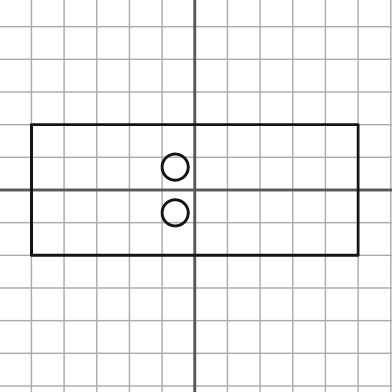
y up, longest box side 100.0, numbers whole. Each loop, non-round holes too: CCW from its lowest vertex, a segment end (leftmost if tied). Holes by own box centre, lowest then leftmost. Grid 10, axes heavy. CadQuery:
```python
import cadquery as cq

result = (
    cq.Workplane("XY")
    .moveTo(-50.0, -20.0)
    .lineTo(50.0, -20.0)
    .lineTo(50.0, 20.0)
    .lineTo(-50.0, 20.0)
    .close()
    .moveTo(-6.0, -7.0)
    .circle(4.0)
    .moveTo(-6.0, 7.0)
    .circle(4.0)
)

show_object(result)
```